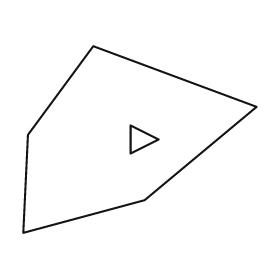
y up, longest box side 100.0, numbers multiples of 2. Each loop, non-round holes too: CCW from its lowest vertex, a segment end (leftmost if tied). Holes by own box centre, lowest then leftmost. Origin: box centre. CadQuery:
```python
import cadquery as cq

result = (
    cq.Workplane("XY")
    .moveTo(-50.0, -40.0)
    .lineTo(2.0, -26.0)
    .lineTo(50.0, 14.0)
    .lineTo(-20.0, 40.0)
    .lineTo(-48.0, 2.0)
    .close()
    .moveTo(-4.0, -6.0)
    .lineTo(8.0, 0.0)
    .lineTo(-4.0, 6.0)
    .close()
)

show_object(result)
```